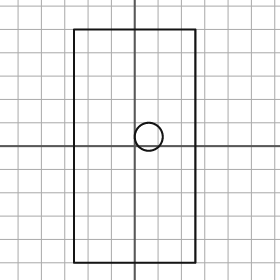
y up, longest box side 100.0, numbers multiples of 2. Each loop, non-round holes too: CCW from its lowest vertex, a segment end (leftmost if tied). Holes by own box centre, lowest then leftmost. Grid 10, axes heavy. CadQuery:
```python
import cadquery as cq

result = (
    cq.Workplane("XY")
    .moveTo(-26.0, -50.0)
    .lineTo(26.0, -50.0)
    .lineTo(26.0, 50.0)
    .lineTo(-26.0, 50.0)
    .close()
    .moveTo(6.0, 4.0)
    .circle(6.0)
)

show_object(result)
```